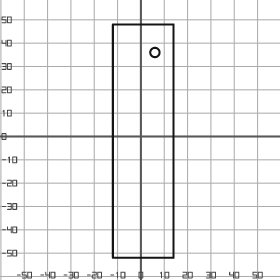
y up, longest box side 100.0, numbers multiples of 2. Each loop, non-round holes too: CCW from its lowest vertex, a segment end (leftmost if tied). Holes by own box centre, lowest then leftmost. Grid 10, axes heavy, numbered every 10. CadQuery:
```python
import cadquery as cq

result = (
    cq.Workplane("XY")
    .moveTo(-12.0, -52.0)
    .lineTo(14.0, -52.0)
    .lineTo(14.0, 48.0)
    .lineTo(-12.0, 48.0)
    .close()
    .moveTo(6.0, 36.0)
    .circle(2.0)
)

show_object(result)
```